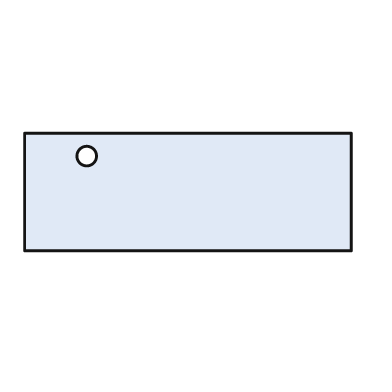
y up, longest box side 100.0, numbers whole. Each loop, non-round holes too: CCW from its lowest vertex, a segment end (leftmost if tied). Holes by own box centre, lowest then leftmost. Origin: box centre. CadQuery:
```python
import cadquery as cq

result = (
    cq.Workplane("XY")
    .moveTo(-50.0, -18.0)
    .lineTo(50.0, -18.0)
    .lineTo(50.0, 18.0)
    .lineTo(-50.0, 18.0)
    .close()
    .moveTo(-31.0, 11.0)
    .circle(3.0)
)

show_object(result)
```